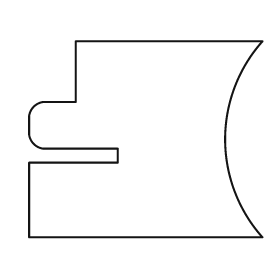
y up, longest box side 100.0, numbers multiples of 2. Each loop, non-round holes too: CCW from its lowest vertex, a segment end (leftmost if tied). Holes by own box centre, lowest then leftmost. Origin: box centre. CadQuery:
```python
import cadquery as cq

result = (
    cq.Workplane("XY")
    .moveTo(-50.0, -42.0)
    .lineTo(50.0, -42.0)
    .threePointArc((34.0, 0.0), (50.0, 42.0))
    .lineTo(-30.0, 42.0)
    .lineTo(-30.0, 16.0)
    .lineTo(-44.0, 16.0)
    .threePointArc((-48.0, 14.0), (-50.0, 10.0))
    .lineTo(-50.0, 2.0)
    .threePointArc((-48.0, -2.0), (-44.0, -4.0))
    .lineTo(-12.0, -4.0)
    .lineTo(-12.0, -10.0)
    .lineTo(-50.0, -10.0)
    .close()
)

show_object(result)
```